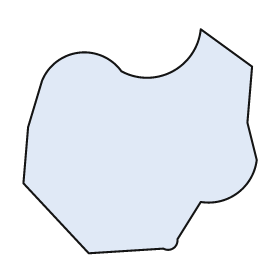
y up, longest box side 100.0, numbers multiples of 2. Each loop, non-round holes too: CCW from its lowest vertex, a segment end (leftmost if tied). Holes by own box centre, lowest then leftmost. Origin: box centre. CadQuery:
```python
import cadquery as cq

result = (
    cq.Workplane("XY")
    .moveTo(-22.0, -48.0)
    .lineTo(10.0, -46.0)
    .threePointArc((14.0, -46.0), (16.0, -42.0))
    .lineTo(26.0, -26.0)
    .threePointArc((42.0, -22.0), (50.0, -8.0))
    .lineTo(46.0, 8.0)
    .lineTo(48.0, 32.0)
    .lineTo(26.0, 48.0)
    .threePointArc((14.0, 30.0), (-8.0, 30.0))
    .threePointArc((-26.0, 38.0), (-42.0, 26.0))
    .lineTo(-48.0, 6.0)
    .lineTo(-50.0, -18.0)
    .close()
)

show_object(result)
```